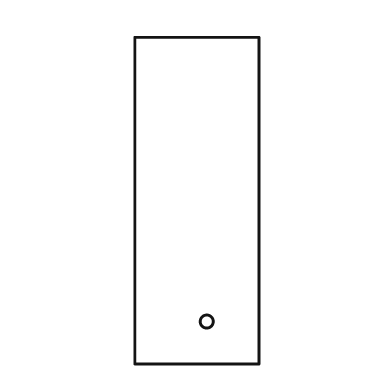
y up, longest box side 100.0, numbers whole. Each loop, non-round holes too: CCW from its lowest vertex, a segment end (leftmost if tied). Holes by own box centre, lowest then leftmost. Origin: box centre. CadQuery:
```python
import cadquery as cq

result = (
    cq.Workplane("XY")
    .moveTo(-19.0, -50.0)
    .lineTo(19.0, -50.0)
    .lineTo(19.0, 50.0)
    .lineTo(-19.0, 50.0)
    .close()
    .moveTo(3.0, -37.0)
    .circle(2.0)
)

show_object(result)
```